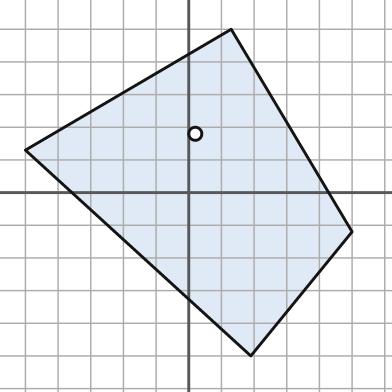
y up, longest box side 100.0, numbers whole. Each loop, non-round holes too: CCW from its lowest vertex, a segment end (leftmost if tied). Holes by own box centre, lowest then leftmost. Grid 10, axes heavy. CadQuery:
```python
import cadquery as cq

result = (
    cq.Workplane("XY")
    .moveTo(19.0, -50.0)
    .lineTo(50.0, -12.0)
    .lineTo(13.0, 50.0)
    .lineTo(-50.0, 13.0)
    .close()
    .moveTo(2.0, 18.0)
    .circle(2.0)
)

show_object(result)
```